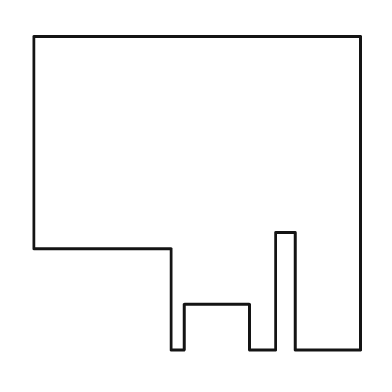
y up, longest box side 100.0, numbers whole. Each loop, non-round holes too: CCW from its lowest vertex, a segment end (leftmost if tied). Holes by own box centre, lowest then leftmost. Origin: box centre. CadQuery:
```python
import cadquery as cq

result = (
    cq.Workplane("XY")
    .moveTo(-8.0, -48.0)
    .lineTo(-4.0, -48.0)
    .lineTo(-4.0, -34.0)
    .lineTo(16.0, -34.0)
    .lineTo(16.0, -48.0)
    .lineTo(24.0, -48.0)
    .lineTo(24.0, -12.0)
    .lineTo(30.0, -12.0)
    .lineTo(30.0, -48.0)
    .lineTo(50.0, -48.0)
    .lineTo(50.0, 48.0)
    .lineTo(-50.0, 48.0)
    .lineTo(-50.0, -17.0)
    .lineTo(-8.0, -17.0)
    .close()
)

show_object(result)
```